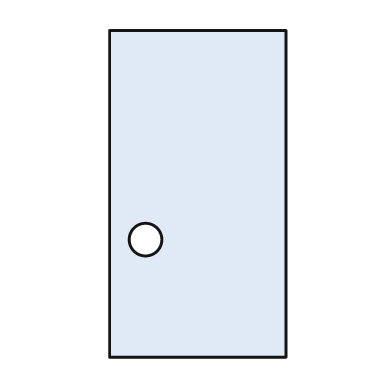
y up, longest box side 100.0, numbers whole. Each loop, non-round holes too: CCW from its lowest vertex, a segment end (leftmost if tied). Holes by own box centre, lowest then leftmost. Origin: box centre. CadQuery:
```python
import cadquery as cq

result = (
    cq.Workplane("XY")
    .moveTo(-27.0, -50.0)
    .lineTo(27.0, -50.0)
    .lineTo(27.0, 50.0)
    .lineTo(-27.0, 50.0)
    .close()
    .moveTo(-16.0, -14.0)
    .circle(5.0)
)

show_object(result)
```